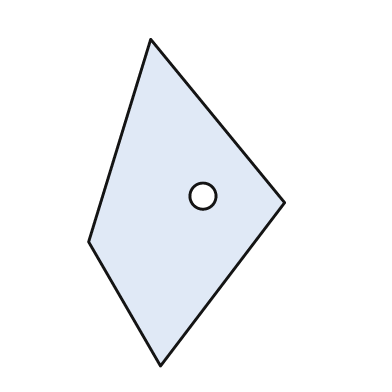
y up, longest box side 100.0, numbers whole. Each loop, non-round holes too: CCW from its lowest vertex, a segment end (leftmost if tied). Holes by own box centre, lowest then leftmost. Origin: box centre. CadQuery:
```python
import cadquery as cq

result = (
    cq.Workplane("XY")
    .moveTo(-8.0, -50.0)
    .lineTo(30.0, 0.0)
    .lineTo(-11.0, 50.0)
    .lineTo(-30.0, -12.0)
    .close()
    .moveTo(5.0, 2.0)
    .circle(4.0)
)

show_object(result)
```